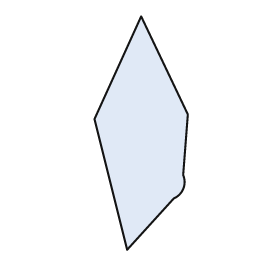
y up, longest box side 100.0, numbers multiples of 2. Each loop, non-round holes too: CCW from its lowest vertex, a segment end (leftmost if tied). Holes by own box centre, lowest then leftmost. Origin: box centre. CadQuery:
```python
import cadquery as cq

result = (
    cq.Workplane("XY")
    .moveTo(-6.0, -50.0)
    .lineTo(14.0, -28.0)
    .threePointArc((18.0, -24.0), (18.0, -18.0))
    .lineTo(20.0, 8.0)
    .lineTo(0.0, 50.0)
    .lineTo(-20.0, 6.0)
    .close()
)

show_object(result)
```